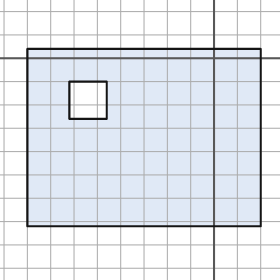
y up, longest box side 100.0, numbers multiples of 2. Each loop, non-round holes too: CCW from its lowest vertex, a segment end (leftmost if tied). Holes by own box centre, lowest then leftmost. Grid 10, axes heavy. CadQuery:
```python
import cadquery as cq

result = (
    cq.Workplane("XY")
    .moveTo(-80.0, -72.0)
    .lineTo(20.0, -72.0)
    .lineTo(20.0, 4.0)
    .lineTo(-80.0, 4.0)
    .close()
    .moveTo(-62.0, -26.0)
    .lineTo(-46.0, -26.0)
    .lineTo(-46.0, -10.0)
    .lineTo(-62.0, -10.0)
    .close()
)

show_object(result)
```